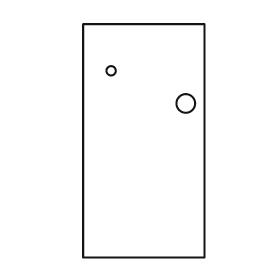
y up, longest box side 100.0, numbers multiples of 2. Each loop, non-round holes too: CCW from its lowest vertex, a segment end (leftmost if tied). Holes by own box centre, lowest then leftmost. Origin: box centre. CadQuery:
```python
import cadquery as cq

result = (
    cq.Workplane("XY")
    .moveTo(-26.0, -50.0)
    .lineTo(26.0, -50.0)
    .lineTo(26.0, 50.0)
    .lineTo(-26.0, 50.0)
    .close()
    .moveTo(18.0, 16.0)
    .circle(4.0)
    .moveTo(-14.0, 30.0)
    .circle(2.0)
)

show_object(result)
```